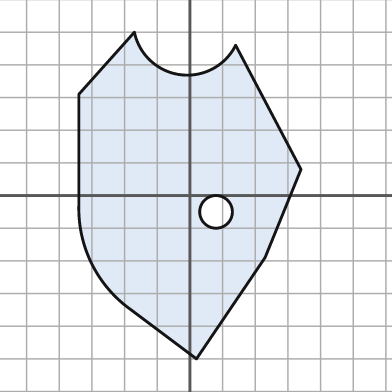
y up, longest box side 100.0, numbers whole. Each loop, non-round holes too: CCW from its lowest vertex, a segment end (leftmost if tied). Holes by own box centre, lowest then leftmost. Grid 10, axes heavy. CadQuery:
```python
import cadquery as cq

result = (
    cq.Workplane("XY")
    .moveTo(2.0, -50.0)
    .lineTo(23.0, -19.0)
    .lineTo(34.0, 8.0)
    .lineTo(14.0, 46.0)
    .threePointArc((-3.0, 37.0), (-17.0, 50.0))
    .lineTo(-34.0, 31.0)
    .lineTo(-34.0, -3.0)
    .threePointArc((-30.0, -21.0), (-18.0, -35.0))
    .close()
    .moveTo(8.0, -5.0)
    .circle(5.0)
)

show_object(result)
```